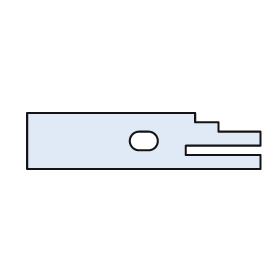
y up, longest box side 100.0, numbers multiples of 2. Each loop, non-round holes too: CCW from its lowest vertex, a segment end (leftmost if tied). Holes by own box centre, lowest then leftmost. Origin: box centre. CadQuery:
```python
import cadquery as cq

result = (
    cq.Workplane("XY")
    .moveTo(-50.0, -12.0)
    .lineTo(50.0, -12.0)
    .lineTo(50.0, -6.0)
    .lineTo(18.0, -6.0)
    .lineTo(18.0, -2.0)
    .lineTo(50.0, -2.0)
    .lineTo(50.0, 4.0)
    .lineTo(32.0, 4.0)
    .lineTo(32.0, 8.0)
    .lineTo(22.0, 8.0)
    .lineTo(22.0, 12.0)
    .lineTo(-50.0, 12.0)
    .close()
    .moveTo(-2.0, -4.0)
    .lineTo(2.0, -4.0)
    .threePointArc((6.0, 0.0), (2.0, 4.0))
    .lineTo(-2.0, 4.0)
    .threePointArc((-6.0, 0.0), (-2.0, -4.0))
    .close()
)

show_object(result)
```